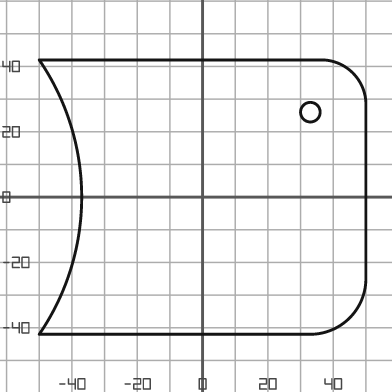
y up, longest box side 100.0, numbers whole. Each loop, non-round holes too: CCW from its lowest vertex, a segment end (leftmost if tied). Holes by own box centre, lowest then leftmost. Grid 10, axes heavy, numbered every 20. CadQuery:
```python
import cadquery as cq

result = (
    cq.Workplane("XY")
    .moveTo(-50.0, -42.0)
    .lineTo(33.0, -42.0)
    .threePointArc((45.0, -37.0), (50.0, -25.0))
    .lineTo(50.0, 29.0)
    .threePointArc((46.0, 38.0), (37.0, 42.0))
    .lineTo(-50.0, 42.0)
    .threePointArc((-37.0, 0.0), (-50.0, -42.0))
    .close()
    .moveTo(33.0, 26.0)
    .circle(3.0)
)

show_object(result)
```